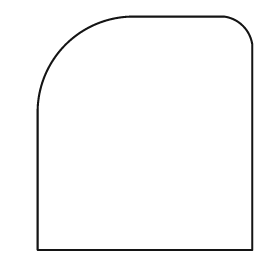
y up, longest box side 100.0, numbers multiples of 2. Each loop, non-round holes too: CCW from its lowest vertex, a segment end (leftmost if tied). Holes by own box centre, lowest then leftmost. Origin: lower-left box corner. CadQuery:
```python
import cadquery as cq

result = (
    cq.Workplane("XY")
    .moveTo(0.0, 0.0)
    .lineTo(92.0, 0.0)
    .lineTo(92.0, 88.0)
    .threePointArc((88.0, 96.0), (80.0, 100.0))
    .lineTo(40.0, 100.0)
    .threePointArc((12.0, 88.0), (0.0, 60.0))
    .close()
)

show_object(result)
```